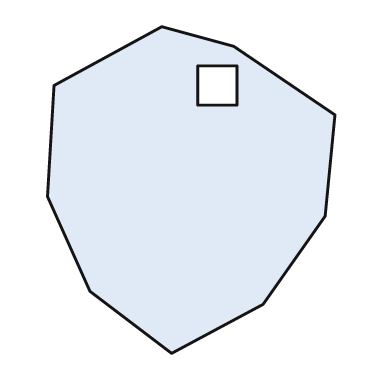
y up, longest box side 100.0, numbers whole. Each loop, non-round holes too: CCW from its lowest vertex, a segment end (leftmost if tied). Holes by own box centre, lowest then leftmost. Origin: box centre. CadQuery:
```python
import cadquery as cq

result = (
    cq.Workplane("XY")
    .moveTo(-6.0, -50.0)
    .lineTo(22.0, -35.0)
    .lineTo(41.0, -8.0)
    .lineTo(44.0, 23.0)
    .lineTo(13.0, 44.0)
    .lineTo(-9.0, 50.0)
    .lineTo(-42.0, 32.0)
    .lineTo(-44.0, -2.0)
    .lineTo(-31.0, -31.0)
    .close()
    .moveTo(2.0, 26.0)
    .lineTo(14.0, 26.0)
    .lineTo(14.0, 38.0)
    .lineTo(2.0, 38.0)
    .close()
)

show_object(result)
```